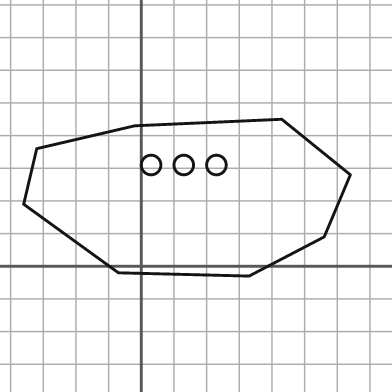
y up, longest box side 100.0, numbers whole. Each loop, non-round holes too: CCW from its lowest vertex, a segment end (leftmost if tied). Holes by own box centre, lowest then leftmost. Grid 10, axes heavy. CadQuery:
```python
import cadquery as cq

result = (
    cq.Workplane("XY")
    .moveTo(33.0, -3.0)
    .lineTo(56.0, 9.0)
    .lineTo(64.0, 28.0)
    .lineTo(43.0, 45.0)
    .lineTo(-2.0, 43.0)
    .lineTo(-32.0, 36.0)
    .lineTo(-36.0, 19.0)
    .lineTo(-7.0, -2.0)
    .close()
    .moveTo(3.0, 31.0)
    .circle(3.0)
    .moveTo(13.0, 31.0)
    .circle(3.0)
    .moveTo(23.0, 31.0)
    .circle(3.0)
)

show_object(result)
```